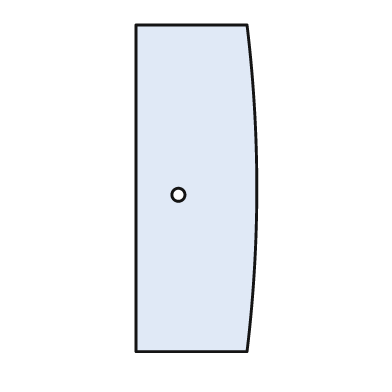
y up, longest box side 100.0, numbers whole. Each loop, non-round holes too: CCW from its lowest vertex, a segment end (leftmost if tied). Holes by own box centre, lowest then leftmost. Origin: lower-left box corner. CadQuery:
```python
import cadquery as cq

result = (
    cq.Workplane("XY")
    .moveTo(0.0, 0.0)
    .lineTo(34.0, 0.0)
    .threePointArc((37.0, 50.0), (34.0, 100.0))
    .lineTo(0.0, 100.0)
    .close()
    .moveTo(13.0, 48.0)
    .circle(2.0)
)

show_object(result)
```